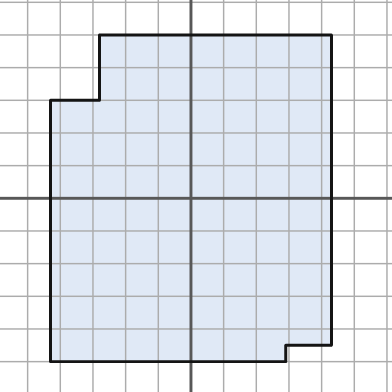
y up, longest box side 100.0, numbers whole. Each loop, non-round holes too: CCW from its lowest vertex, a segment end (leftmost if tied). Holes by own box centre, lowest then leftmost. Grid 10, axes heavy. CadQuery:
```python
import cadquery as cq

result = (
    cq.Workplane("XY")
    .moveTo(-43.0, -50.0)
    .lineTo(29.0, -50.0)
    .lineTo(29.0, -45.0)
    .lineTo(43.0, -45.0)
    .lineTo(43.0, 50.0)
    .lineTo(-28.0, 50.0)
    .lineTo(-28.0, 30.0)
    .lineTo(-43.0, 30.0)
    .close()
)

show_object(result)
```